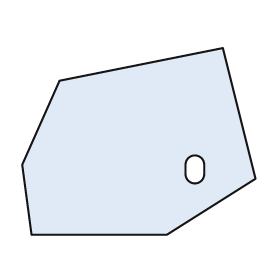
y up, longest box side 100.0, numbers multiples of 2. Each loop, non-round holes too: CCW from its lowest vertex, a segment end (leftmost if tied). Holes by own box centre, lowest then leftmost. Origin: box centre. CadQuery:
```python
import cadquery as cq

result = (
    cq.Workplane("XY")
    .moveTo(-46.0, -40.0)
    .lineTo(12.0, -40.0)
    .lineTo(50.0, -16.0)
    .lineTo(36.0, 40.0)
    .lineTo(-34.0, 26.0)
    .lineTo(-50.0, -10.0)
    .close()
    .moveTo(20.0, -14.0)
    .threePointArc((24.0, -18.0), (28.0, -14.0))
    .lineTo(28.0, -10.0)
    .threePointArc((24.0, -6.0), (20.0, -10.0))
    .close()
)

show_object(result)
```